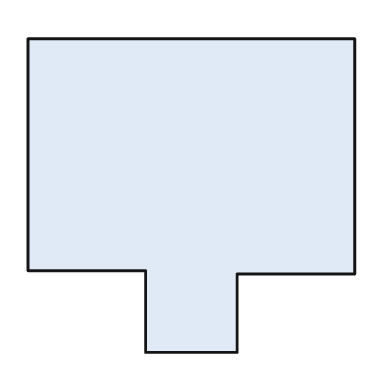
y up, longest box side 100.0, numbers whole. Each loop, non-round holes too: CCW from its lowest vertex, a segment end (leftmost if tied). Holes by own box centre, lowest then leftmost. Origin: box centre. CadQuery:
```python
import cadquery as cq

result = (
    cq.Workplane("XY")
    .moveTo(-14.0, -48.0)
    .lineTo(14.0, -48.0)
    .lineTo(14.0, -24.0)
    .lineTo(50.0, -24.0)
    .lineTo(50.0, 48.0)
    .lineTo(-50.0, 48.0)
    .lineTo(-50.0, -23.0)
    .lineTo(-14.0, -23.0)
    .close()
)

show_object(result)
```